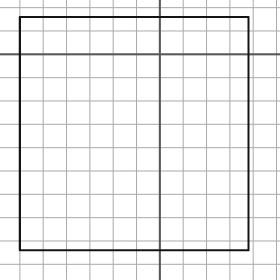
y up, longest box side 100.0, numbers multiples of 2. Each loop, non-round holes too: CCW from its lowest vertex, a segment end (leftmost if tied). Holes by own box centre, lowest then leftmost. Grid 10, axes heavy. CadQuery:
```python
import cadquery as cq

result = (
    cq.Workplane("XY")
    .moveTo(-60.0, -84.0)
    .lineTo(38.0, -84.0)
    .lineTo(38.0, 16.0)
    .lineTo(-60.0, 16.0)
    .close()
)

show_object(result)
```